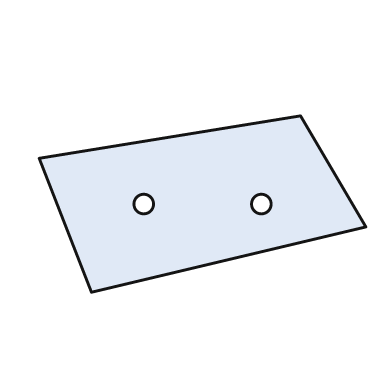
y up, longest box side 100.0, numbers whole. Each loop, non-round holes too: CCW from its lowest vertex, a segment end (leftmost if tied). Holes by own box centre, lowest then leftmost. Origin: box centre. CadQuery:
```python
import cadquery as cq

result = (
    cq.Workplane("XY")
    .moveTo(-34.0, -27.0)
    .lineTo(50.0, -7.0)
    .lineTo(30.0, 27.0)
    .lineTo(-50.0, 14.0)
    .close()
    .moveTo(-18.0, 0.0)
    .circle(3.0)
    .moveTo(18.0, 0.0)
    .circle(3.0)
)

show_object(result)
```